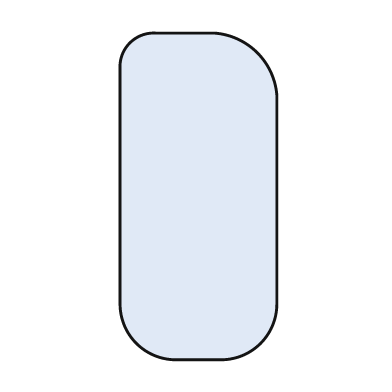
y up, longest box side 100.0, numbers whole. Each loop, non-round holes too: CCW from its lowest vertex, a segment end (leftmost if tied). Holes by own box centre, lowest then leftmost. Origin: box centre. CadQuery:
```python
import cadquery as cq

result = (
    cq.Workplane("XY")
    .moveTo(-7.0, -50.0)
    .lineTo(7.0, -50.0)
    .threePointArc((19.0, -45.0), (24.0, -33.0))
    .lineTo(24.0, 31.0)
    .threePointArc((18.0, 44.0), (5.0, 50.0))
    .lineTo(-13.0, 50.0)
    .threePointArc((-21.0, 47.0), (-24.0, 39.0))
    .lineTo(-24.0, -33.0)
    .threePointArc((-19.0, -45.0), (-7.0, -50.0))
    .close()
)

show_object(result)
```